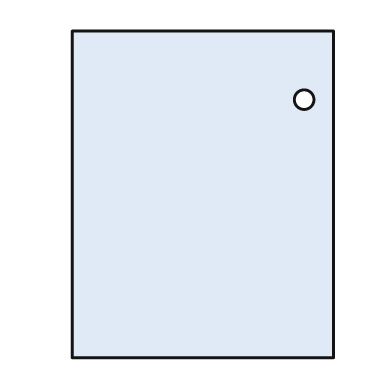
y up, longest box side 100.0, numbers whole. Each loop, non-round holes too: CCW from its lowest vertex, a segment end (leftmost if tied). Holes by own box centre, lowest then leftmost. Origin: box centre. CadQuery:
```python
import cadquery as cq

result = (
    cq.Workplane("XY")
    .moveTo(-40.0, -50.0)
    .lineTo(40.0, -50.0)
    .lineTo(40.0, 50.0)
    .lineTo(-40.0, 50.0)
    .close()
    .moveTo(31.0, 29.0)
    .circle(3.0)
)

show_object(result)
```